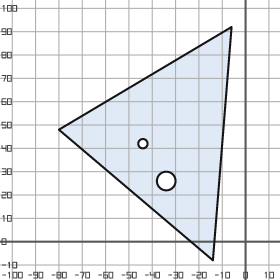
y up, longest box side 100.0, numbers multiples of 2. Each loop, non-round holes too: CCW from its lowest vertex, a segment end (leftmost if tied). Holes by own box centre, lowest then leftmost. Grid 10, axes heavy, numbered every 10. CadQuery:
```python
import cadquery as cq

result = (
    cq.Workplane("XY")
    .moveTo(-14.0, -8.0)
    .lineTo(-6.0, 92.0)
    .lineTo(-80.0, 48.0)
    .close()
    .moveTo(-34.0, 26.0)
    .circle(4.0)
    .moveTo(-44.0, 42.0)
    .circle(2.0)
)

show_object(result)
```